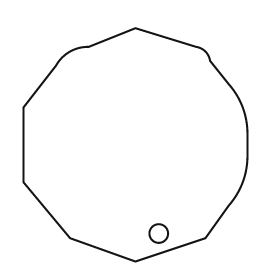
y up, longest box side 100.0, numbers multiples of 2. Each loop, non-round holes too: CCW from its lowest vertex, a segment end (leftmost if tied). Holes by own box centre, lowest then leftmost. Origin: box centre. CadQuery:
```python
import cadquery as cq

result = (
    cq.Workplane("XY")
    .moveTo(0.0, -50.0)
    .lineTo(30.0, -40.0)
    .lineTo(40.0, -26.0)
    .threePointArc((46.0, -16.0), (48.0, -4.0))
    .lineTo(48.0, 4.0)
    .threePointArc((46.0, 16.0), (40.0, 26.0))
    .lineTo(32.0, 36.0)
    .threePointArc((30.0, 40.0), (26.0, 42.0))
    .lineTo(0.0, 50.0)
    .lineTo(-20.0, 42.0)
    .threePointArc((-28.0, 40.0), (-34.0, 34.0))
    .lineTo(-48.0, 16.0)
    .lineTo(-48.0, -16.0)
    .lineTo(-28.0, -40.0)
    .close()
    .moveTo(10.0, -38.0)
    .circle(4.0)
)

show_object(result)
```